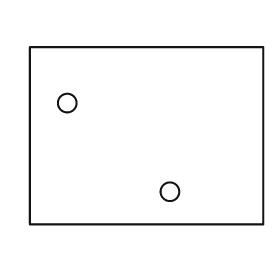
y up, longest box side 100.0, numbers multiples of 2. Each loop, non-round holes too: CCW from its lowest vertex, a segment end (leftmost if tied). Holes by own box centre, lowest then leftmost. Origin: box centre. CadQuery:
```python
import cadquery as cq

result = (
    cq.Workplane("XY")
    .moveTo(-50.0, -38.0)
    .lineTo(50.0, -38.0)
    .lineTo(50.0, 38.0)
    .lineTo(-50.0, 38.0)
    .close()
    .moveTo(10.0, -24.0)
    .circle(4.0)
    .moveTo(-34.0, 14.0)
    .circle(4.0)
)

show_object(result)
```